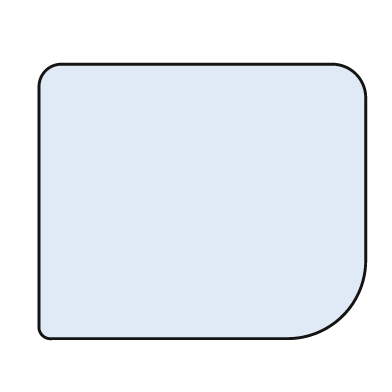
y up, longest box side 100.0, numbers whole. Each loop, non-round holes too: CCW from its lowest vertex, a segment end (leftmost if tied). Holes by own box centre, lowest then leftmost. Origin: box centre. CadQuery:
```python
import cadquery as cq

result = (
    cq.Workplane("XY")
    .moveTo(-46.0, -42.0)
    .lineTo(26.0, -42.0)
    .threePointArc((43.0, -35.0), (50.0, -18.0))
    .lineTo(50.0, 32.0)
    .threePointArc((47.0, 39.0), (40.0, 42.0))
    .lineTo(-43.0, 42.0)
    .threePointArc((-48.0, 40.0), (-50.0, 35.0))
    .lineTo(-50.0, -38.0)
    .threePointArc((-49.0, -41.0), (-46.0, -42.0))
    .close()
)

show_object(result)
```